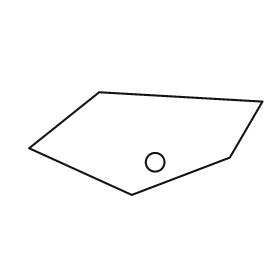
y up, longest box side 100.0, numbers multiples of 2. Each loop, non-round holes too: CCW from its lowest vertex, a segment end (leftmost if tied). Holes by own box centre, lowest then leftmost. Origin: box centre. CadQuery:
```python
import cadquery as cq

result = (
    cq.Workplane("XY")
    .moveTo(-6.0, -22.0)
    .lineTo(36.0, -6.0)
    .lineTo(50.0, 18.0)
    .lineTo(-20.0, 22.0)
    .lineTo(-50.0, -2.0)
    .close()
    .moveTo(4.0, -8.0)
    .circle(4.0)
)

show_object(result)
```